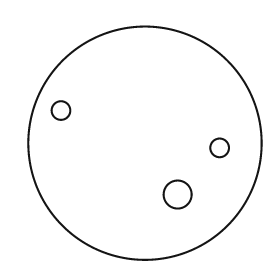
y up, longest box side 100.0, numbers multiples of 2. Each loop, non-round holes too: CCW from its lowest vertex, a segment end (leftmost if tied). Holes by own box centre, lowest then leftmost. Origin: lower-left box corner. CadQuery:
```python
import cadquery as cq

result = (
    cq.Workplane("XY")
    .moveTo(50.0, 50.0)
    .circle(50.0)
    .moveTo(64.0, 28.0)
    .circle(6.0)
    .moveTo(82.0, 48.0)
    .circle(4.0)
    .moveTo(14.0, 64.0)
    .circle(4.0)
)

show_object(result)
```